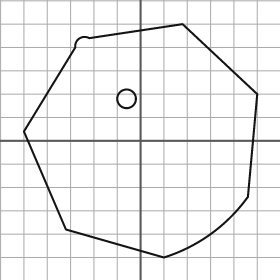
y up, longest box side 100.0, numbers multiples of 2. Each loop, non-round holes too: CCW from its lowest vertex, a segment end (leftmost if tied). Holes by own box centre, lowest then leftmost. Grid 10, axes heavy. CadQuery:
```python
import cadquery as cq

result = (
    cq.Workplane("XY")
    .moveTo(10.0, -50.0)
    .threePointArc((30.0, -40.0), (46.0, -24.0))
    .lineTo(50.0, 20.0)
    .lineTo(18.0, 50.0)
    .lineTo(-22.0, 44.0)
    .threePointArc((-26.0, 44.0), (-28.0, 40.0))
    .lineTo(-50.0, 4.0)
    .lineTo(-32.0, -38.0)
    .close()
    .moveTo(-6.0, 18.0)
    .circle(4.0)
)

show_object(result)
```